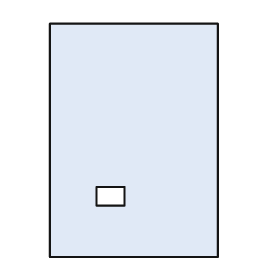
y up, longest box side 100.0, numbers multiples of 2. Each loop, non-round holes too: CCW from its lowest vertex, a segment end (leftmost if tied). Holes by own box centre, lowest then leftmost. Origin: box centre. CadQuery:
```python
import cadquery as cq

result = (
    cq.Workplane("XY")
    .moveTo(-36.0, -50.0)
    .lineTo(36.0, -50.0)
    .lineTo(36.0, 50.0)
    .lineTo(-36.0, 50.0)
    .close()
    .moveTo(-16.0, -28.0)
    .lineTo(-4.0, -28.0)
    .lineTo(-4.0, -20.0)
    .lineTo(-16.0, -20.0)
    .close()
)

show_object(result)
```